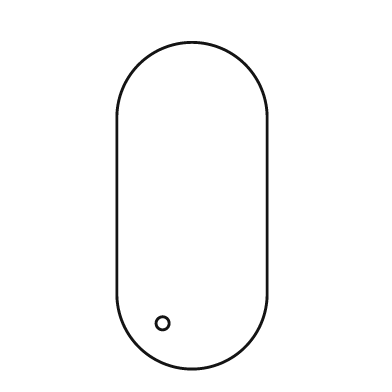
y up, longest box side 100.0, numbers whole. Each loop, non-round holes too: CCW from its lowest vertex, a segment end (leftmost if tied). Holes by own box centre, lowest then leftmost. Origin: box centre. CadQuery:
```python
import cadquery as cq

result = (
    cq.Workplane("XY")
    .moveTo(-23.0, -27.0)
    .threePointArc((0.0, -50.0), (23.0, -27.0))
    .lineTo(23.0, 27.0)
    .threePointArc((0.0, 50.0), (-23.0, 27.0))
    .close()
    .moveTo(-9.0, -36.0)
    .circle(2.0)
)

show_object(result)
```